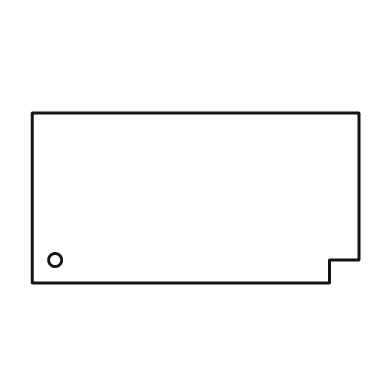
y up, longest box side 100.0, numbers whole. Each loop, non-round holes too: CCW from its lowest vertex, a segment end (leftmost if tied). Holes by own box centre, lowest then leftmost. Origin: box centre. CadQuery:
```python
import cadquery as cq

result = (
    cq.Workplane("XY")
    .moveTo(-50.0, -26.0)
    .lineTo(41.0, -26.0)
    .lineTo(41.0, -19.0)
    .lineTo(50.0, -19.0)
    .lineTo(50.0, 26.0)
    .lineTo(-50.0, 26.0)
    .close()
    .moveTo(-43.0, -19.0)
    .circle(2.0)
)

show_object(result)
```